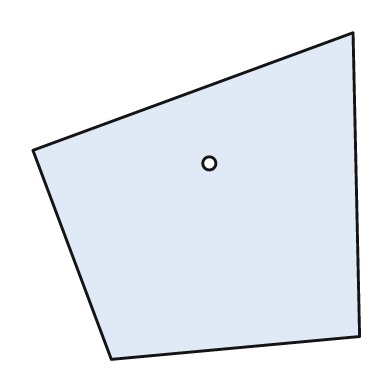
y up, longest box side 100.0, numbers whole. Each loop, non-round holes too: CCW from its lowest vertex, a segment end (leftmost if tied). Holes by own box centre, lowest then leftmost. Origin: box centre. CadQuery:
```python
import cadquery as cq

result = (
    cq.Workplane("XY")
    .moveTo(-26.0, -50.0)
    .lineTo(50.0, -43.0)
    .lineTo(48.0, 50.0)
    .lineTo(-50.0, 14.0)
    .close()
    .moveTo(4.0, 10.0)
    .circle(2.0)
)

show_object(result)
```